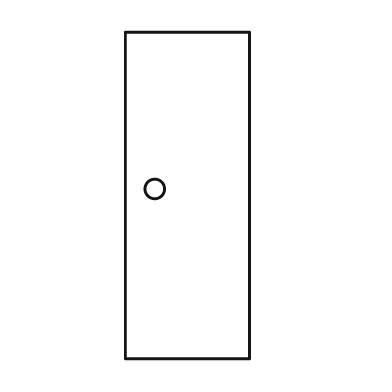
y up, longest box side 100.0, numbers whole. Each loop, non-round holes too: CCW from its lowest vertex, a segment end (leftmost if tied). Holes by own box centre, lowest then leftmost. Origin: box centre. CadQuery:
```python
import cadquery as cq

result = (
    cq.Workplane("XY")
    .moveTo(-19.0, -50.0)
    .lineTo(19.0, -50.0)
    .lineTo(19.0, 50.0)
    .lineTo(-19.0, 50.0)
    .close()
    .moveTo(-10.0, 2.0)
    .circle(3.0)
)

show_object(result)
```